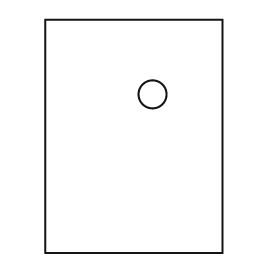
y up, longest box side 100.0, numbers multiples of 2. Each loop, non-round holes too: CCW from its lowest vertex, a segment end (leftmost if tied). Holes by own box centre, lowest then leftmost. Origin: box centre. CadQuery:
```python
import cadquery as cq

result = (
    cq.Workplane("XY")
    .moveTo(-38.0, -50.0)
    .lineTo(38.0, -50.0)
    .lineTo(38.0, 50.0)
    .lineTo(-38.0, 50.0)
    .close()
    .moveTo(8.0, 18.0)
    .circle(6.0)
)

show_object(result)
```